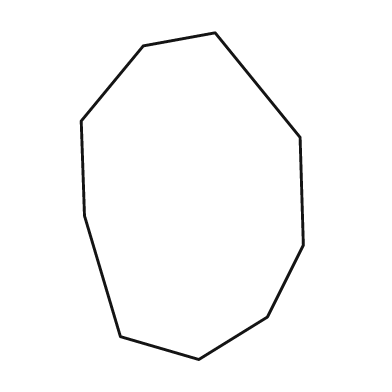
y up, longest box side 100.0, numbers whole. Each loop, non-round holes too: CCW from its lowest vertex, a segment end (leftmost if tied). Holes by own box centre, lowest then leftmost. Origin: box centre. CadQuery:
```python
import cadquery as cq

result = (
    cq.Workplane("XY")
    .moveTo(2.0, -50.0)
    .lineTo(23.0, -37.0)
    .lineTo(34.0, -15.0)
    .lineTo(33.0, 18.0)
    .lineTo(7.0, 50.0)
    .lineTo(-15.0, 46.0)
    .lineTo(-34.0, 23.0)
    .lineTo(-33.0, -6.0)
    .lineTo(-22.0, -43.0)
    .close()
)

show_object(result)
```